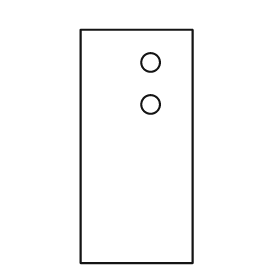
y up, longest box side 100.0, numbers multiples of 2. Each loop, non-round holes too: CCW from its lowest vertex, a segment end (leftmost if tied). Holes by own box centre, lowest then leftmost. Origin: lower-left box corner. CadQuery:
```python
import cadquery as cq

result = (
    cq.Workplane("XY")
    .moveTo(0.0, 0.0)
    .lineTo(48.0, 0.0)
    .lineTo(48.0, 100.0)
    .lineTo(0.0, 100.0)
    .close()
    .moveTo(30.0, 68.0)
    .circle(4.0)
    .moveTo(30.0, 86.0)
    .circle(4.0)
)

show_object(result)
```